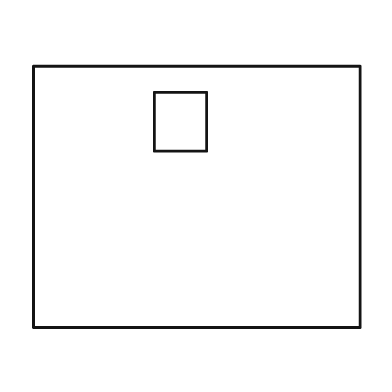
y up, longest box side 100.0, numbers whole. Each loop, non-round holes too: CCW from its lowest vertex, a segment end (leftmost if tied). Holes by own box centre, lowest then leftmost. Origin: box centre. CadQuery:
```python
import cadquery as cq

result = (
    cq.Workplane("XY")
    .moveTo(-50.0, -40.0)
    .lineTo(50.0, -40.0)
    .lineTo(50.0, 40.0)
    .lineTo(-50.0, 40.0)
    .close()
    .moveTo(-13.0, 14.0)
    .lineTo(3.0, 14.0)
    .lineTo(3.0, 32.0)
    .lineTo(-13.0, 32.0)
    .close()
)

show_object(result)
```